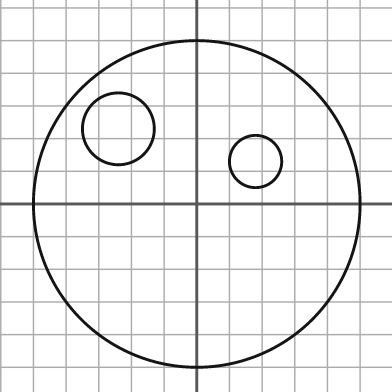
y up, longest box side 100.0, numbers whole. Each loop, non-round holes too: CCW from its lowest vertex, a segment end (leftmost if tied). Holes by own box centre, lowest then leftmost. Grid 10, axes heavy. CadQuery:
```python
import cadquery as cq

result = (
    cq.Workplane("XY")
    .moveTo(0.0, 0.0)
    .circle(50.0)
    .moveTo(18.0, 13.0)
    .circle(8.0)
    .moveTo(-24.0, 23.0)
    .circle(11.0)
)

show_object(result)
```